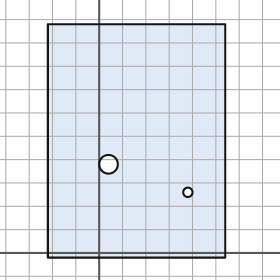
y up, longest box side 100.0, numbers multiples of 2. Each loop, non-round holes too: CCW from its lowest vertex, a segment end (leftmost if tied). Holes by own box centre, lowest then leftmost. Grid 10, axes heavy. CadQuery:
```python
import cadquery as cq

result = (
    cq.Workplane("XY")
    .moveTo(-22.0, -2.0)
    .lineTo(54.0, -2.0)
    .lineTo(54.0, 98.0)
    .lineTo(-22.0, 98.0)
    .close()
    .moveTo(38.0, 26.0)
    .circle(2.0)
    .moveTo(4.0, 38.0)
    .circle(4.0)
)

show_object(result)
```